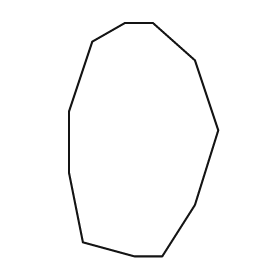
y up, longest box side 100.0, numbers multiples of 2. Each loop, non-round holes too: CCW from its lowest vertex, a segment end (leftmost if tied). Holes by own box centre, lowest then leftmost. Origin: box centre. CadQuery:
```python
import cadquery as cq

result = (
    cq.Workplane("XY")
    .moveTo(-4.0, -50.0)
    .lineTo(8.0, -50.0)
    .lineTo(22.0, -28.0)
    .lineTo(32.0, 4.0)
    .lineTo(22.0, 34.0)
    .lineTo(4.0, 50.0)
    .lineTo(-8.0, 50.0)
    .lineTo(-22.0, 42.0)
    .lineTo(-32.0, 12.0)
    .lineTo(-32.0, -14.0)
    .lineTo(-26.0, -44.0)
    .close()
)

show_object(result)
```